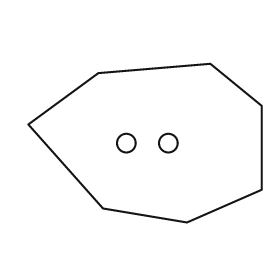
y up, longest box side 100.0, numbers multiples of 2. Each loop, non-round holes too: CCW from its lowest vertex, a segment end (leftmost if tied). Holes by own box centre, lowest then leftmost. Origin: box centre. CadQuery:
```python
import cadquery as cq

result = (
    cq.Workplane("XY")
    .moveTo(18.0, -34.0)
    .lineTo(50.0, -20.0)
    .lineTo(50.0, 16.0)
    .lineTo(28.0, 34.0)
    .lineTo(-20.0, 30.0)
    .lineTo(-50.0, 8.0)
    .lineTo(-18.0, -28.0)
    .close()
    .moveTo(-8.0, 0.0)
    .circle(4.0)
    .moveTo(10.0, 0.0)
    .circle(4.0)
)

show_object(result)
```